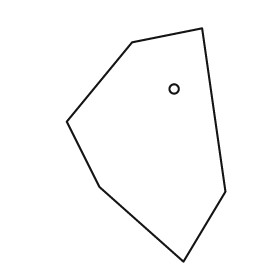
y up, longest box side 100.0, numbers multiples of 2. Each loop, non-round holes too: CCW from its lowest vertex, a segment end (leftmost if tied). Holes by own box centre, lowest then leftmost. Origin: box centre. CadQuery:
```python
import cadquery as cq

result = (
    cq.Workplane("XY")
    .moveTo(16.0, -50.0)
    .lineTo(34.0, -20.0)
    .lineTo(24.0, 50.0)
    .lineTo(-6.0, 44.0)
    .lineTo(-34.0, 10.0)
    .lineTo(-20.0, -18.0)
    .close()
    .moveTo(12.0, 24.0)
    .circle(2.0)
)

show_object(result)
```